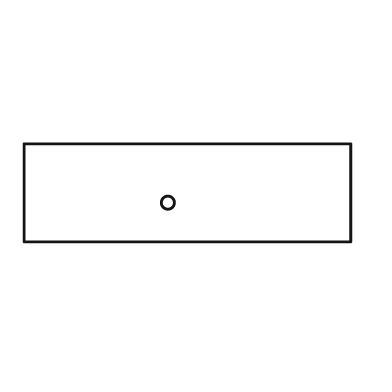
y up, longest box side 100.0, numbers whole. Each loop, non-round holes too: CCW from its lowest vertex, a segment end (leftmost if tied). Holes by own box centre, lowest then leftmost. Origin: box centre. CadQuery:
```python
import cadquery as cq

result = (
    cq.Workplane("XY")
    .moveTo(-50.0, -15.0)
    .lineTo(50.0, -15.0)
    .lineTo(50.0, 15.0)
    .lineTo(-50.0, 15.0)
    .close()
    .moveTo(-6.0, -3.0)
    .circle(2.0)
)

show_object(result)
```